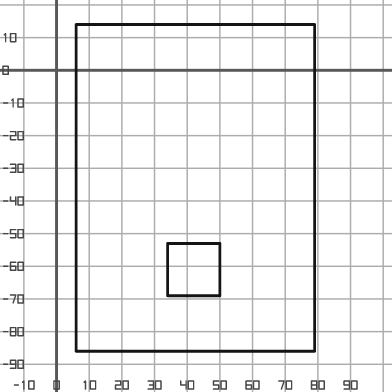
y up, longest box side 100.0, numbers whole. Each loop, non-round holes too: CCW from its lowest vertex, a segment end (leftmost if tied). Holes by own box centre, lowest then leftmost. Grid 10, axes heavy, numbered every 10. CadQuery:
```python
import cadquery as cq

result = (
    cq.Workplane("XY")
    .moveTo(6.0, -86.0)
    .lineTo(79.0, -86.0)
    .lineTo(79.0, 14.0)
    .lineTo(6.0, 14.0)
    .close()
    .moveTo(34.0, -69.0)
    .lineTo(50.0, -69.0)
    .lineTo(50.0, -53.0)
    .lineTo(34.0, -53.0)
    .close()
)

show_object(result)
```